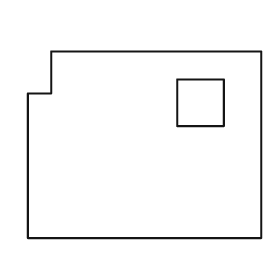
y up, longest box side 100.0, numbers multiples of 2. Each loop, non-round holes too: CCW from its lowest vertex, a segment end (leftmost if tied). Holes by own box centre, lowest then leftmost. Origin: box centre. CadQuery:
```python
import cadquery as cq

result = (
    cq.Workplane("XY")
    .moveTo(-50.0, -40.0)
    .lineTo(50.0, -40.0)
    .lineTo(50.0, 40.0)
    .lineTo(-40.0, 40.0)
    .lineTo(-40.0, 22.0)
    .lineTo(-50.0, 22.0)
    .close()
    .moveTo(14.0, 8.0)
    .lineTo(34.0, 8.0)
    .lineTo(34.0, 28.0)
    .lineTo(14.0, 28.0)
    .close()
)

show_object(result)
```